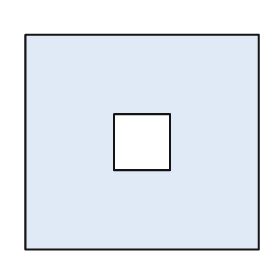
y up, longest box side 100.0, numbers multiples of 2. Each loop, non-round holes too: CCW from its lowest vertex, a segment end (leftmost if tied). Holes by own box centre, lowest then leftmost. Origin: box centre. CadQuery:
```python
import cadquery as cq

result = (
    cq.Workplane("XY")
    .moveTo(-50.0, -46.0)
    .lineTo(50.0, -46.0)
    .lineTo(50.0, 46.0)
    .lineTo(-50.0, 46.0)
    .close()
    .moveTo(-12.0, -12.0)
    .lineTo(12.0, -12.0)
    .lineTo(12.0, 12.0)
    .lineTo(-12.0, 12.0)
    .close()
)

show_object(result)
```